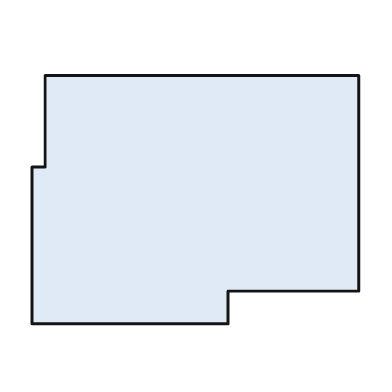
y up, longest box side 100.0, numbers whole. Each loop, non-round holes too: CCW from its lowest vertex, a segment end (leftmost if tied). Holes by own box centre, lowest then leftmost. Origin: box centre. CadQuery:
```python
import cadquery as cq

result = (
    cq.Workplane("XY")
    .moveTo(-50.0, -38.0)
    .lineTo(10.0, -38.0)
    .lineTo(10.0, -28.0)
    .lineTo(50.0, -28.0)
    .lineTo(50.0, 38.0)
    .lineTo(-46.0, 38.0)
    .lineTo(-46.0, 10.0)
    .lineTo(-50.0, 10.0)
    .close()
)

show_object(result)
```